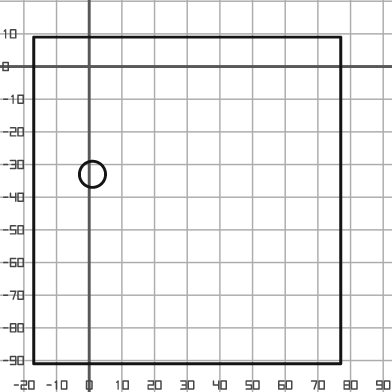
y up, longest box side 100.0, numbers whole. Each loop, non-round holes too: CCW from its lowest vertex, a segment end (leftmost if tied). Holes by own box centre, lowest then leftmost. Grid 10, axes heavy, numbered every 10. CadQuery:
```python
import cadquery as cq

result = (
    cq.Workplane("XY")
    .moveTo(-17.0, -91.0)
    .lineTo(77.0, -91.0)
    .lineTo(77.0, 9.0)
    .lineTo(-17.0, 9.0)
    .close()
    .moveTo(1.0, -33.0)
    .circle(4.0)
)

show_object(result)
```